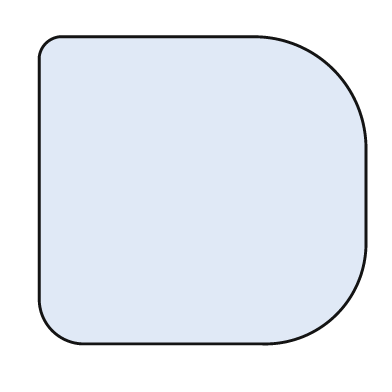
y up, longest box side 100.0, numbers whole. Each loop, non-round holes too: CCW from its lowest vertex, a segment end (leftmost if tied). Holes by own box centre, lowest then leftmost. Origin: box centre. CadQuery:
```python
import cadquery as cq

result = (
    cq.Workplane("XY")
    .moveTo(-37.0, -47.0)
    .lineTo(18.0, -47.0)
    .threePointArc((41.0, -38.0), (50.0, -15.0))
    .lineTo(50.0, 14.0)
    .threePointArc((40.0, 37.0), (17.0, 47.0))
    .lineTo(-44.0, 47.0)
    .threePointArc((-48.0, 45.0), (-50.0, 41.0))
    .lineTo(-50.0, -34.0)
    .threePointArc((-46.0, -43.0), (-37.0, -47.0))
    .close()
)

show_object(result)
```